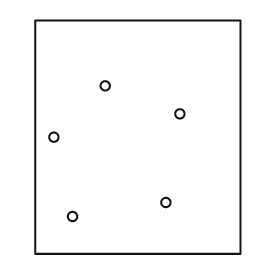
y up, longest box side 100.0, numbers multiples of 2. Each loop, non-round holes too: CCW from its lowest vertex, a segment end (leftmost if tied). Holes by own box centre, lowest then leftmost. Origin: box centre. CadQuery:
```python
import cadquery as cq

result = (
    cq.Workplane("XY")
    .moveTo(-44.0, -50.0)
    .lineTo(44.0, -50.0)
    .lineTo(44.0, 50.0)
    .lineTo(-44.0, 50.0)
    .close()
    .moveTo(-28.0, -34.0)
    .circle(2.0)
    .moveTo(12.0, -28.0)
    .circle(2.0)
    .moveTo(-36.0, 0.0)
    .circle(2.0)
    .moveTo(18.0, 10.0)
    .circle(2.0)
    .moveTo(-14.0, 22.0)
    .circle(2.0)
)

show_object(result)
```